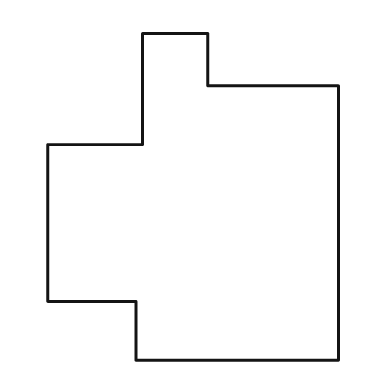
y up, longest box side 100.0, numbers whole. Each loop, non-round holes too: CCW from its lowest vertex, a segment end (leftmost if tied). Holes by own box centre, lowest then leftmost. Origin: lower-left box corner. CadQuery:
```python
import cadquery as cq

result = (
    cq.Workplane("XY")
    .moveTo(27.0, 0.0)
    .lineTo(89.0, 0.0)
    .lineTo(89.0, 84.0)
    .lineTo(49.0, 84.0)
    .lineTo(49.0, 100.0)
    .lineTo(29.0, 100.0)
    .lineTo(29.0, 66.0)
    .lineTo(0.0, 66.0)
    .lineTo(0.0, 18.0)
    .lineTo(27.0, 18.0)
    .close()
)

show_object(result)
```